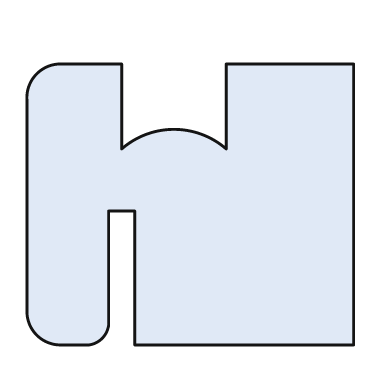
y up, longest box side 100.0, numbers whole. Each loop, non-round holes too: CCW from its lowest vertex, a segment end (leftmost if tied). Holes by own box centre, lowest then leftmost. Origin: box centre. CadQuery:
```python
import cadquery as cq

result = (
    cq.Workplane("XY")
    .moveTo(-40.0, -43.0)
    .lineTo(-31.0, -43.0)
    .threePointArc((-27.0, -41.0), (-25.0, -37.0))
    .lineTo(-25.0, -2.0)
    .lineTo(-17.0, -2.0)
    .lineTo(-17.0, -43.0)
    .lineTo(50.0, -43.0)
    .lineTo(50.0, 43.0)
    .lineTo(11.0, 43.0)
    .lineTo(11.0, 17.0)
    .threePointArc((-5.0, 23.0), (-21.0, 17.0))
    .lineTo(-21.0, 43.0)
    .lineTo(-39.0, 43.0)
    .threePointArc((-47.0, 40.0), (-50.0, 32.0))
    .lineTo(-50.0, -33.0)
    .threePointArc((-47.0, -40.0), (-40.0, -43.0))
    .close()
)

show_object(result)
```